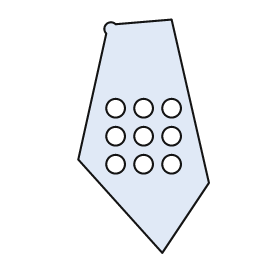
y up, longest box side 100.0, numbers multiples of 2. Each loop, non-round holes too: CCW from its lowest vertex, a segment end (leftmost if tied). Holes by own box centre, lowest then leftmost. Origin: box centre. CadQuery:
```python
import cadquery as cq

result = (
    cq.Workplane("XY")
    .moveTo(8.0, -50.0)
    .lineTo(28.0, -20.0)
    .lineTo(12.0, 50.0)
    .lineTo(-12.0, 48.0)
    .threePointArc((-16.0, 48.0), (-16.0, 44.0))
    .lineTo(-28.0, -10.0)
    .close()
    .moveTo(-12.0, -12.0)
    .circle(4.0)
    .moveTo(0.0, -12.0)
    .circle(4.0)
    .moveTo(12.0, -12.0)
    .circle(4.0)
    .moveTo(-12.0, 0.0)
    .circle(4.0)
    .moveTo(0.0, 0.0)
    .circle(4.0)
    .moveTo(12.0, 0.0)
    .circle(4.0)
    .moveTo(-12.0, 12.0)
    .circle(4.0)
    .moveTo(0.0, 12.0)
    .circle(4.0)
    .moveTo(12.0, 12.0)
    .circle(4.0)
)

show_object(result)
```